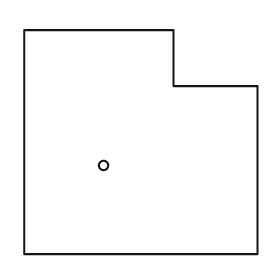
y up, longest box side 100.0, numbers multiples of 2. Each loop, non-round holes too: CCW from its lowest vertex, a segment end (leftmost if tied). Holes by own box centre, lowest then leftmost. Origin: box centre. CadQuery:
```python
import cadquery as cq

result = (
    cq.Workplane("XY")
    .moveTo(-50.0, -48.0)
    .lineTo(50.0, -48.0)
    .lineTo(50.0, 24.0)
    .lineTo(14.0, 24.0)
    .lineTo(14.0, 48.0)
    .lineTo(-50.0, 48.0)
    .close()
    .moveTo(-16.0, -10.0)
    .circle(2.0)
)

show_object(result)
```